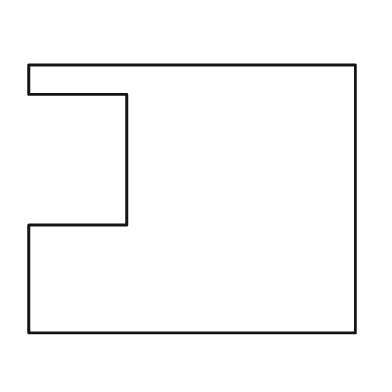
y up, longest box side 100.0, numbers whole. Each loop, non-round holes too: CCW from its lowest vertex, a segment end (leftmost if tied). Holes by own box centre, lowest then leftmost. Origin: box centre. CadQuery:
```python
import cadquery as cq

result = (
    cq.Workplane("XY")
    .moveTo(-50.0, -41.0)
    .lineTo(50.0, -41.0)
    .lineTo(50.0, 41.0)
    .lineTo(-50.0, 41.0)
    .lineTo(-50.0, 32.0)
    .lineTo(-20.0, 32.0)
    .lineTo(-20.0, -8.0)
    .lineTo(-50.0, -8.0)
    .close()
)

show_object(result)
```